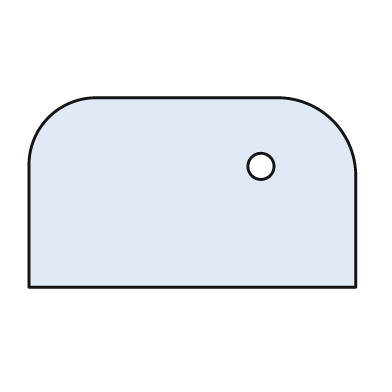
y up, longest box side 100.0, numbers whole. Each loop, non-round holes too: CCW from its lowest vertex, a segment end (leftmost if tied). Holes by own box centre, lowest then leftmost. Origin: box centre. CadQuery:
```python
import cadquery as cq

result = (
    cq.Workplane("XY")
    .moveTo(-50.0, -29.0)
    .lineTo(50.0, -29.0)
    .lineTo(50.0, 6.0)
    .threePointArc((43.0, 22.0), (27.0, 29.0))
    .lineTo(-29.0, 29.0)
    .threePointArc((-44.0, 23.0), (-50.0, 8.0))
    .close()
    .moveTo(21.0, 8.0)
    .circle(4.0)
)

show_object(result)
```